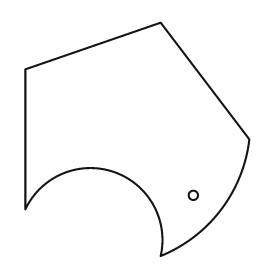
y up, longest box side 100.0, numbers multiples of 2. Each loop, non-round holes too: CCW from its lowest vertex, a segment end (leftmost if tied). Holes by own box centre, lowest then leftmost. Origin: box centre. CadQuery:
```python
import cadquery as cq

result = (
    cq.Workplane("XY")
    .moveTo(10.0, -50.0)
    .threePointArc((36.0, -30.0), (48.0, 0.0))
    .lineTo(10.0, 50.0)
    .lineTo(-48.0, 30.0)
    .lineTo(-48.0, -30.0)
    .threePointArc((-10.0, -14.0), (10.0, -50.0))
    .close()
    .moveTo(24.0, -24.0)
    .circle(2.0)
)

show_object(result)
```